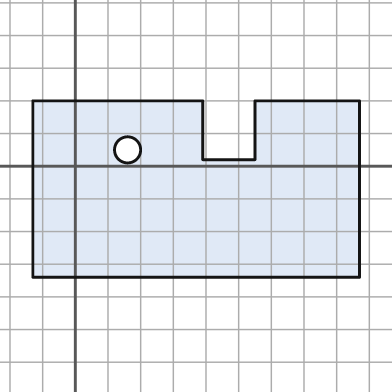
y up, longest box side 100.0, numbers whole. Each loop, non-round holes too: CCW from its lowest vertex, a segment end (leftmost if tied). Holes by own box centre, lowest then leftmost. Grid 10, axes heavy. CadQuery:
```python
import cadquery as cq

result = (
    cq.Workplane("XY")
    .moveTo(-13.0, -34.0)
    .lineTo(87.0, -34.0)
    .lineTo(87.0, 20.0)
    .lineTo(55.0, 20.0)
    .lineTo(55.0, 2.0)
    .lineTo(39.0, 2.0)
    .lineTo(39.0, 20.0)
    .lineTo(-13.0, 20.0)
    .close()
    .moveTo(16.0, 5.0)
    .circle(4.0)
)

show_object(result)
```